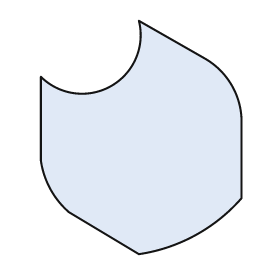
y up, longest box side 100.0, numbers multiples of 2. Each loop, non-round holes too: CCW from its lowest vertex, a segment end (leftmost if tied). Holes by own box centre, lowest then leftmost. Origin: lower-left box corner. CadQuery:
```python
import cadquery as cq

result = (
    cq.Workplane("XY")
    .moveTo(42.0, 0.0)
    .threePointArc((66.0, 8.0), (86.0, 24.0))
    .lineTo(86.0, 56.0)
    .threePointArc((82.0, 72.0), (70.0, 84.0))
    .lineTo(42.0, 100.0)
    .threePointArc((30.0, 72.0), (0.0, 76.0))
    .lineTo(0.0, 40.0)
    .threePointArc((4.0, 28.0), (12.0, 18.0))
    .close()
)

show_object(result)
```